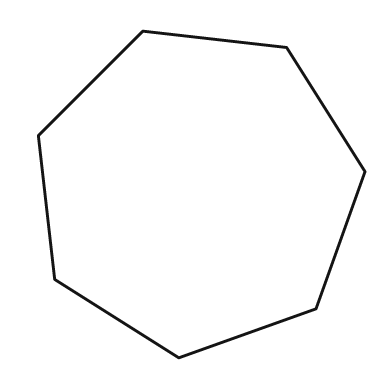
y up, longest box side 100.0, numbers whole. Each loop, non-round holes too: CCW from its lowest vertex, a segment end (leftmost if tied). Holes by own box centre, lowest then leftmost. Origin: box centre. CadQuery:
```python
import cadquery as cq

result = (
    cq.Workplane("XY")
    .moveTo(-7.0, -50.0)
    .lineTo(35.0, -35.0)
    .lineTo(50.0, 7.0)
    .lineTo(26.0, 45.0)
    .lineTo(-18.0, 50.0)
    .lineTo(-50.0, 18.0)
    .lineTo(-45.0, -26.0)
    .close()
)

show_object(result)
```